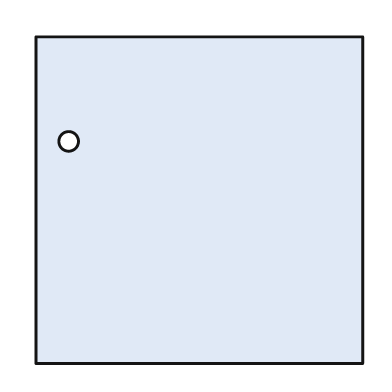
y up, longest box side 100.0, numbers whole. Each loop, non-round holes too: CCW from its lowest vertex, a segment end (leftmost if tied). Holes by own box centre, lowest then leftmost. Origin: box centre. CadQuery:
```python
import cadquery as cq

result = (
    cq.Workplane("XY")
    .moveTo(-50.0, -50.0)
    .lineTo(50.0, -50.0)
    .lineTo(50.0, 50.0)
    .lineTo(-50.0, 50.0)
    .close()
    .moveTo(-40.0, 18.0)
    .circle(3.0)
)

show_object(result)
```